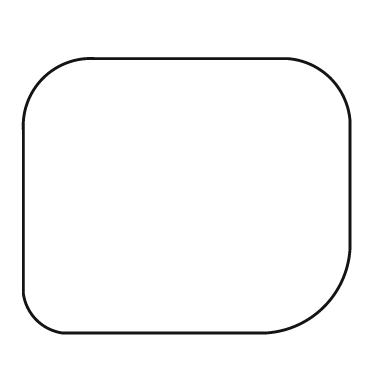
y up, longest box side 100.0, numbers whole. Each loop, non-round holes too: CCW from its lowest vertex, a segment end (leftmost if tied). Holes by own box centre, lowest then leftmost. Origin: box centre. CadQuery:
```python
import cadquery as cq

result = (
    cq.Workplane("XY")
    .moveTo(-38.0, -42.0)
    .lineTo(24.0, -42.0)
    .threePointArc((42.0, -34.0), (50.0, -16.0))
    .lineTo(50.0, 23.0)
    .threePointArc((44.0, 36.0), (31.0, 42.0))
    .lineTo(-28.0, 42.0)
    .threePointArc((-44.0, 36.0), (-50.0, 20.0))
    .lineTo(-50.0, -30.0)
    .threePointArc((-46.0, -38.0), (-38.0, -42.0))
    .close()
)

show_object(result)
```